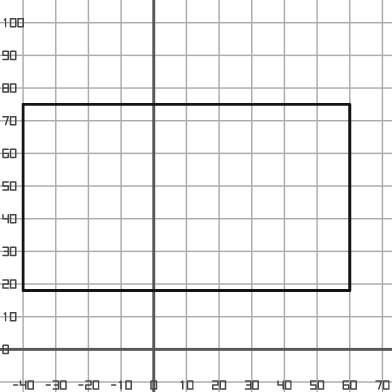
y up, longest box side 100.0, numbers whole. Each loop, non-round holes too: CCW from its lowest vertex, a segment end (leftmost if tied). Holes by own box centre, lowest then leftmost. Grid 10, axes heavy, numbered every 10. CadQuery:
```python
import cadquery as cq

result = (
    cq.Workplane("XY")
    .moveTo(-40.0, 18.0)
    .lineTo(60.0, 18.0)
    .lineTo(60.0, 75.0)
    .lineTo(-40.0, 75.0)
    .close()
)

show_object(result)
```